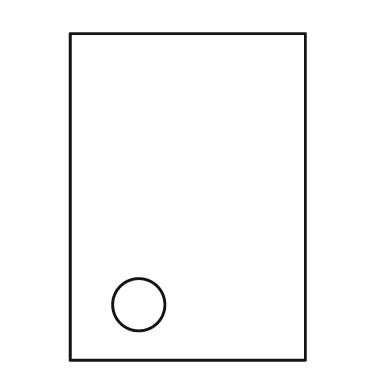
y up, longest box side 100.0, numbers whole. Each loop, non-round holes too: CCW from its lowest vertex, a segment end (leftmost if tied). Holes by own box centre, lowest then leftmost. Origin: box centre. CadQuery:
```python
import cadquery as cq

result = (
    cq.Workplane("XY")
    .moveTo(-36.0, -50.0)
    .lineTo(36.0, -50.0)
    .lineTo(36.0, 50.0)
    .lineTo(-36.0, 50.0)
    .close()
    .moveTo(-15.0, -33.0)
    .circle(8.0)
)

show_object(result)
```